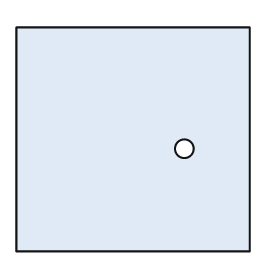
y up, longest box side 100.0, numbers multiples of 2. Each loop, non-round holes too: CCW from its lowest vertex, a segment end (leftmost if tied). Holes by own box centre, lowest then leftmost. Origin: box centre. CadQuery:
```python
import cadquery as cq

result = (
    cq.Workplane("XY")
    .moveTo(-50.0, -48.0)
    .lineTo(50.0, -48.0)
    .lineTo(50.0, 48.0)
    .lineTo(-50.0, 48.0)
    .close()
    .moveTo(22.0, -4.0)
    .circle(4.0)
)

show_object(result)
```